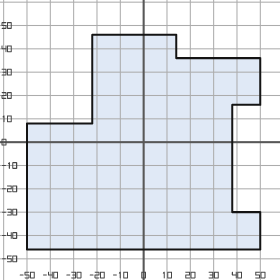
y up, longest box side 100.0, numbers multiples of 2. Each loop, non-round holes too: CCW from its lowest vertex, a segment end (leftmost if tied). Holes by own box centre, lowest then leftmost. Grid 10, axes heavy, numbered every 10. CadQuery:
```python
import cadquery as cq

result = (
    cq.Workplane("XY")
    .moveTo(-50.0, -46.0)
    .lineTo(50.0, -46.0)
    .lineTo(50.0, -30.0)
    .lineTo(38.0, -30.0)
    .lineTo(38.0, 16.0)
    .lineTo(50.0, 16.0)
    .lineTo(50.0, 36.0)
    .lineTo(14.0, 36.0)
    .lineTo(14.0, 46.0)
    .lineTo(-22.0, 46.0)
    .lineTo(-22.0, 8.0)
    .lineTo(-50.0, 8.0)
    .close()
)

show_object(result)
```